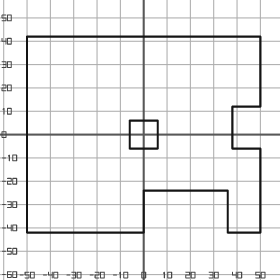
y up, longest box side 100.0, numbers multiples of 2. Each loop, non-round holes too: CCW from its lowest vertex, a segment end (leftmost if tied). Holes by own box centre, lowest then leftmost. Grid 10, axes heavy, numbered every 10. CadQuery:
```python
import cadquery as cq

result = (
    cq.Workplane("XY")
    .moveTo(-50.0, -42.0)
    .lineTo(0.0, -42.0)
    .lineTo(0.0, -24.0)
    .lineTo(36.0, -24.0)
    .lineTo(36.0, -42.0)
    .lineTo(50.0, -42.0)
    .lineTo(50.0, -6.0)
    .lineTo(38.0, -6.0)
    .lineTo(38.0, 12.0)
    .lineTo(50.0, 12.0)
    .lineTo(50.0, 42.0)
    .lineTo(-50.0, 42.0)
    .close()
    .moveTo(-6.0, -6.0)
    .lineTo(6.0, -6.0)
    .lineTo(6.0, 6.0)
    .lineTo(-6.0, 6.0)
    .close()
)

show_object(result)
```